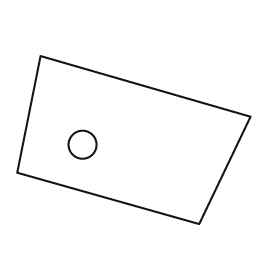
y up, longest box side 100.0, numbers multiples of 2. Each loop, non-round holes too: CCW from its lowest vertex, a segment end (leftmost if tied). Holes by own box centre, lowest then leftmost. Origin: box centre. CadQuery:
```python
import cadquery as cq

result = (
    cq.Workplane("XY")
    .moveTo(28.0, -36.0)
    .lineTo(50.0, 10.0)
    .lineTo(-40.0, 36.0)
    .lineTo(-50.0, -14.0)
    .close()
    .moveTo(-22.0, -2.0)
    .circle(6.0)
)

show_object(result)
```